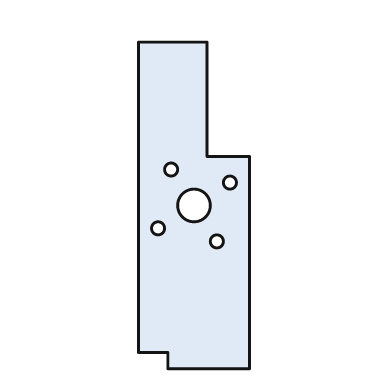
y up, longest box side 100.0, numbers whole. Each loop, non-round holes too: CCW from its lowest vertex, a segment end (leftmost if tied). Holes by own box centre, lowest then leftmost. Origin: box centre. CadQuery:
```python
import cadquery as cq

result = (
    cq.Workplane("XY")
    .moveTo(-8.0, -50.0)
    .lineTo(17.0, -50.0)
    .lineTo(17.0, 15.0)
    .lineTo(4.0, 15.0)
    .lineTo(4.0, 50.0)
    .lineTo(-17.0, 50.0)
    .lineTo(-17.0, -45.0)
    .lineTo(-8.0, -45.0)
    .close()
    .moveTo(7.0, -11.0)
    .circle(2.0)
    .moveTo(-11.0, -7.0)
    .circle(2.0)
    .moveTo(0.0, 0.0)
    .circle(5.0)
    .moveTo(11.0, 7.0)
    .circle(2.0)
    .moveTo(-7.0, 11.0)
    .circle(2.0)
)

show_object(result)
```